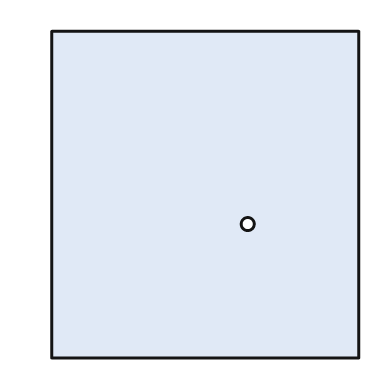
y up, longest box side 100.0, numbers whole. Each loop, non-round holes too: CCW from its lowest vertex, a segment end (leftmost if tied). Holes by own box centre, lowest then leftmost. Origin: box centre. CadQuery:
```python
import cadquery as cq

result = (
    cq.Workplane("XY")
    .moveTo(-47.0, -50.0)
    .lineTo(47.0, -50.0)
    .lineTo(47.0, 50.0)
    .lineTo(-47.0, 50.0)
    .close()
    .moveTo(13.0, -9.0)
    .circle(2.0)
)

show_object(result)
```